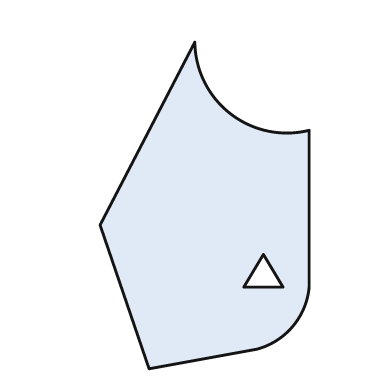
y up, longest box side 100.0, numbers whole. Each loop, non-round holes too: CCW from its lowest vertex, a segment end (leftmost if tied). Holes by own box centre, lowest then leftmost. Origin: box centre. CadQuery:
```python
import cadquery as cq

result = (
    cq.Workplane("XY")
    .moveTo(-17.0, -50.0)
    .lineTo(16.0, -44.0)
    .threePointArc((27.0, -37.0), (32.0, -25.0))
    .lineTo(32.0, 23.0)
    .threePointArc((8.0, 28.0), (-3.0, 50.0))
    .lineTo(-32.0, -6.0)
    .close()
    .moveTo(12.0, -25.0)
    .lineTo(24.0, -25.0)
    .lineTo(18.0, -15.0)
    .close()
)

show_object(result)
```